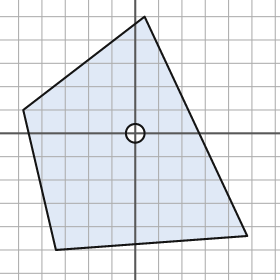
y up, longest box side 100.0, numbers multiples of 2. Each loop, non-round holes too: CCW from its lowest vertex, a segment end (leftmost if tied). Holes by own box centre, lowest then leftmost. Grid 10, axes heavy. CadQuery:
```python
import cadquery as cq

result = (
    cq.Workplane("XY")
    .moveTo(-34.0, -50.0)
    .lineTo(48.0, -44.0)
    .lineTo(4.0, 50.0)
    .lineTo(-48.0, 10.0)
    .close()
    .moveTo(0.0, 0.0)
    .circle(4.0)
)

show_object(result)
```